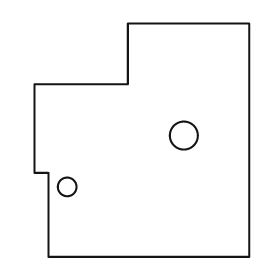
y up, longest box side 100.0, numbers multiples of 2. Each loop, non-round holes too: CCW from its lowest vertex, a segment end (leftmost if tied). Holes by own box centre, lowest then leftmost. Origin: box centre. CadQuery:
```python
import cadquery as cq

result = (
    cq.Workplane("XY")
    .moveTo(-40.0, -50.0)
    .lineTo(46.0, -50.0)
    .lineTo(46.0, 50.0)
    .lineTo(-6.0, 50.0)
    .lineTo(-6.0, 24.0)
    .lineTo(-46.0, 24.0)
    .lineTo(-46.0, -14.0)
    .lineTo(-40.0, -14.0)
    .close()
    .moveTo(-32.0, -20.0)
    .circle(4.0)
    .moveTo(18.0, 2.0)
    .circle(6.0)
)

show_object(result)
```